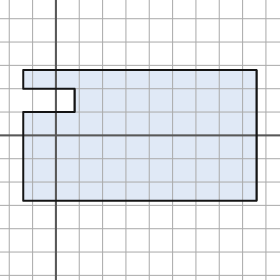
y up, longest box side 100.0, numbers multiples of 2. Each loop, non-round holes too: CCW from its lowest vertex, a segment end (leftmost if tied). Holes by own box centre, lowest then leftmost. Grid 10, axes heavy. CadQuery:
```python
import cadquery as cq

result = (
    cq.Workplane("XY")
    .moveTo(-14.0, -28.0)
    .lineTo(86.0, -28.0)
    .lineTo(86.0, 28.0)
    .lineTo(-14.0, 28.0)
    .lineTo(-14.0, 20.0)
    .lineTo(8.0, 20.0)
    .lineTo(8.0, 10.0)
    .lineTo(-14.0, 10.0)
    .close()
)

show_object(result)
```